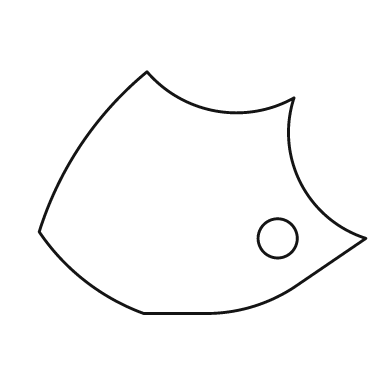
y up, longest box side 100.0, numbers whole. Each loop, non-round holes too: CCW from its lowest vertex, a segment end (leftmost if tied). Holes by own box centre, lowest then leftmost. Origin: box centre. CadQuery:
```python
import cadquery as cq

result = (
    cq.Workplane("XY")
    .moveTo(-18.0, -37.0)
    .lineTo(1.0, -37.0)
    .threePointArc((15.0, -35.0), (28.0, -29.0))
    .lineTo(50.0, -14.0)
    .threePointArc((30.0, 3.0), (28.0, 29.0))
    .threePointArc((4.0, 25.0), (-17.0, 37.0))
    .threePointArc((-37.0, 15.0), (-50.0, -12.0))
    .threePointArc((-36.0, -27.0), (-18.0, -37.0))
    .close()
    .moveTo(23.0, -14.0)
    .circle(6.0)
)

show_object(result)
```